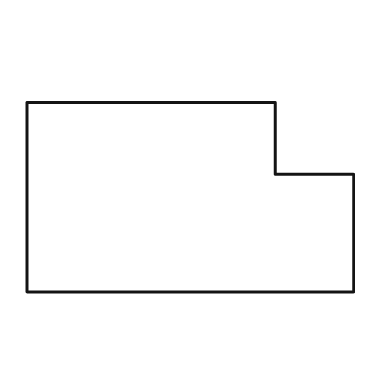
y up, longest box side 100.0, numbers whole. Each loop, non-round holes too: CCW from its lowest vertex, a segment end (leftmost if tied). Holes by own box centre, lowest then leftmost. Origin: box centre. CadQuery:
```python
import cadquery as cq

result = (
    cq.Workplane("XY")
    .moveTo(-50.0, -29.0)
    .lineTo(50.0, -29.0)
    .lineTo(50.0, 7.0)
    .lineTo(26.0, 7.0)
    .lineTo(26.0, 29.0)
    .lineTo(-50.0, 29.0)
    .close()
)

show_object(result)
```